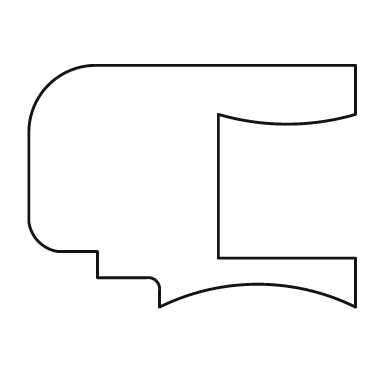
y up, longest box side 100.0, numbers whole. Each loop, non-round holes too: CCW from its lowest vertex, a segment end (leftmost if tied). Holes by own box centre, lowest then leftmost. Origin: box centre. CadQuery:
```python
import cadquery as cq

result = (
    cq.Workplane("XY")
    .moveTo(-10.0, -37.0)
    .threePointArc((20.0, -30.0), (50.0, -37.0))
    .lineTo(50.0, -22.0)
    .lineTo(8.0, -22.0)
    .lineTo(8.0, 22.0)
    .threePointArc((29.0, 19.0), (50.0, 22.0))
    .lineTo(50.0, 37.0)
    .lineTo(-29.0, 37.0)
    .threePointArc((-44.0, 31.0), (-50.0, 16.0))
    .lineTo(-50.0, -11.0)
    .threePointArc((-47.0, -17.0), (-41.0, -20.0))
    .lineTo(-29.0, -20.0)
    .lineTo(-29.0, -28.0)
    .lineTo(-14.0, -28.0)
    .threePointArc((-11.0, -29.0), (-10.0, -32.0))
    .close()
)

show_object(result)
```